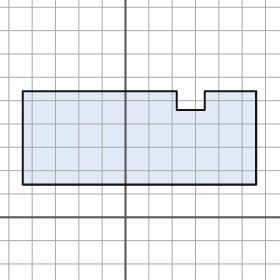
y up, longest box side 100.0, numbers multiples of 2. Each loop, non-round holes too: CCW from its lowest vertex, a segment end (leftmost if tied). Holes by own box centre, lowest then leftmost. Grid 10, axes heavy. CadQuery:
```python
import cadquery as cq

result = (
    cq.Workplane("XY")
    .moveTo(-44.0, 14.0)
    .lineTo(56.0, 14.0)
    .lineTo(56.0, 54.0)
    .lineTo(34.0, 54.0)
    .lineTo(34.0, 46.0)
    .lineTo(22.0, 46.0)
    .lineTo(22.0, 54.0)
    .lineTo(-44.0, 54.0)
    .close()
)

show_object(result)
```